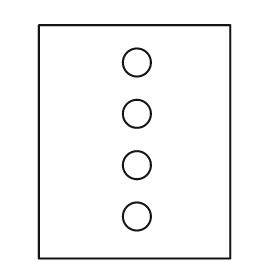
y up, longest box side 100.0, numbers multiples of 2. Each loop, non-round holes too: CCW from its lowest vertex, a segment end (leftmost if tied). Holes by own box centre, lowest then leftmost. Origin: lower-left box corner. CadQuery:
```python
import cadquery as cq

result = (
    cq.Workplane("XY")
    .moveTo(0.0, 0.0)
    .lineTo(82.0, 0.0)
    .lineTo(82.0, 100.0)
    .lineTo(0.0, 100.0)
    .close()
    .moveTo(42.0, 18.0)
    .circle(6.0)
    .moveTo(42.0, 40.0)
    .circle(6.0)
    .moveTo(42.0, 62.0)
    .circle(6.0)
    .moveTo(42.0, 84.0)
    .circle(6.0)
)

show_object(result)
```